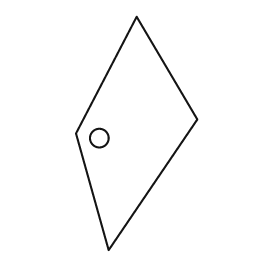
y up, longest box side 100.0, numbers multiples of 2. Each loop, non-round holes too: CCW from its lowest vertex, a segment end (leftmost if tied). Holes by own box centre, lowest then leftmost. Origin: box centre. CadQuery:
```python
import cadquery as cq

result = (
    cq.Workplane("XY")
    .moveTo(-12.0, -50.0)
    .lineTo(26.0, 6.0)
    .lineTo(0.0, 50.0)
    .lineTo(-26.0, 0.0)
    .close()
    .moveTo(-16.0, -2.0)
    .circle(4.0)
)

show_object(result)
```